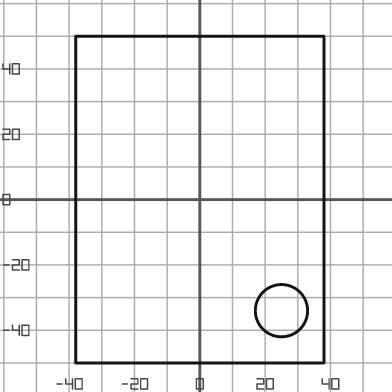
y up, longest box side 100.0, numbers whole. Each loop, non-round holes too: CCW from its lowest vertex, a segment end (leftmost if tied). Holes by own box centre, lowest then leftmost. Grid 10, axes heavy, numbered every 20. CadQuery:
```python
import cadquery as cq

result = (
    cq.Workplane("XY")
    .moveTo(-38.0, -50.0)
    .lineTo(38.0, -50.0)
    .lineTo(38.0, 50.0)
    .lineTo(-38.0, 50.0)
    .close()
    .moveTo(25.0, -34.0)
    .circle(8.0)
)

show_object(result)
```